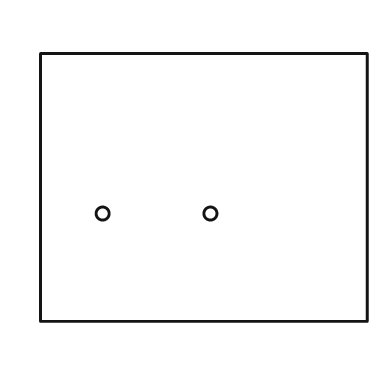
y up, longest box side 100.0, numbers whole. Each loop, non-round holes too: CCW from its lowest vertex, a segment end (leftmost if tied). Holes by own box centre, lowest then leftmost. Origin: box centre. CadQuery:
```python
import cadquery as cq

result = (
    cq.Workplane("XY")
    .moveTo(-50.0, -41.0)
    .lineTo(50.0, -41.0)
    .lineTo(50.0, 41.0)
    .lineTo(-50.0, 41.0)
    .close()
    .moveTo(-31.0, -8.0)
    .circle(2.0)
    .moveTo(2.0, -8.0)
    .circle(2.0)
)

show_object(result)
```